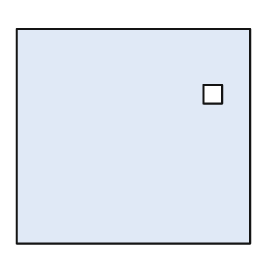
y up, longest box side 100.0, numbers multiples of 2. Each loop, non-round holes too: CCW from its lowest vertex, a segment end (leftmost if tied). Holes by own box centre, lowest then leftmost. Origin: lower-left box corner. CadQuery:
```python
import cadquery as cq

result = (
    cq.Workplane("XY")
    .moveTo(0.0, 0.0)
    .lineTo(100.0, 0.0)
    .lineTo(100.0, 92.0)
    .lineTo(0.0, 92.0)
    .close()
    .moveTo(80.0, 60.0)
    .lineTo(88.0, 60.0)
    .lineTo(88.0, 68.0)
    .lineTo(80.0, 68.0)
    .close()
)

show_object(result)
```